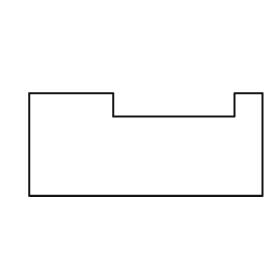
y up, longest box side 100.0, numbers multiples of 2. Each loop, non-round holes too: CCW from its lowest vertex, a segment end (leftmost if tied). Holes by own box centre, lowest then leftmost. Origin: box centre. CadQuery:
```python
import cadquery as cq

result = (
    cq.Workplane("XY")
    .moveTo(-50.0, -22.0)
    .lineTo(50.0, -22.0)
    .lineTo(50.0, 22.0)
    .lineTo(38.0, 22.0)
    .lineTo(38.0, 12.0)
    .lineTo(-14.0, 12.0)
    .lineTo(-14.0, 22.0)
    .lineTo(-50.0, 22.0)
    .close()
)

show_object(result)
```